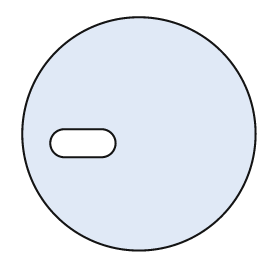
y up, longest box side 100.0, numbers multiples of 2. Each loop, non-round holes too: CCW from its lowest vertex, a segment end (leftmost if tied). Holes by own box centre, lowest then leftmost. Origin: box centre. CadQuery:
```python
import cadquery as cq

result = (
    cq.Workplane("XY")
    .moveTo(0.0, 0.0)
    .circle(50.0)
    .moveTo(-32.0, -10.0)
    .lineTo(-16.0, -10.0)
    .threePointArc((-10.0, -4.0), (-16.0, 2.0))
    .lineTo(-32.0, 2.0)
    .threePointArc((-38.0, -4.0), (-32.0, -10.0))
    .close()
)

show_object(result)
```